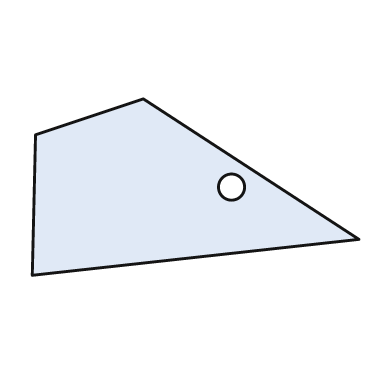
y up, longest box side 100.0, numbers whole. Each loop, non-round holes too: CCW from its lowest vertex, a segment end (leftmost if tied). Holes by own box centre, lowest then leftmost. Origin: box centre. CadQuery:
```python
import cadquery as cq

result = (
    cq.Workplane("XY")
    .moveTo(-50.0, -27.0)
    .lineTo(50.0, -16.0)
    .lineTo(-16.0, 27.0)
    .lineTo(-49.0, 16.0)
    .close()
    .moveTo(11.0, 0.0)
    .circle(4.0)
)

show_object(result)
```